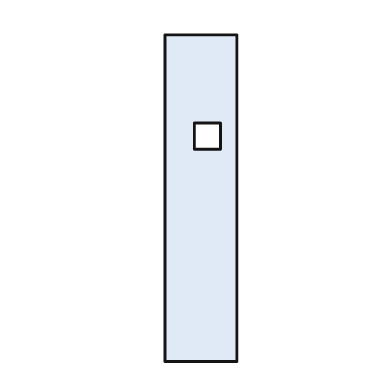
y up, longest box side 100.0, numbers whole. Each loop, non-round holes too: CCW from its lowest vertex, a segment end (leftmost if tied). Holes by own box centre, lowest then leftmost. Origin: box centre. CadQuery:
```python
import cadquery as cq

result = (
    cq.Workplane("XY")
    .moveTo(-11.0, -50.0)
    .lineTo(11.0, -50.0)
    .lineTo(11.0, 50.0)
    .lineTo(-11.0, 50.0)
    .close()
    .moveTo(-2.0, 15.0)
    .lineTo(6.0, 15.0)
    .lineTo(6.0, 23.0)
    .lineTo(-2.0, 23.0)
    .close()
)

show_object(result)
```